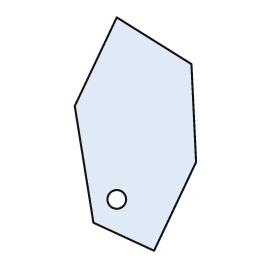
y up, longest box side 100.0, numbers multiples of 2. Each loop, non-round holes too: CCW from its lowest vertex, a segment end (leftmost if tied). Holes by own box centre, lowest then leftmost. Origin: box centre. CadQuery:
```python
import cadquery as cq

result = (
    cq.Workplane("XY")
    .moveTo(8.0, -50.0)
    .lineTo(26.0, -12.0)
    .lineTo(24.0, 30.0)
    .lineTo(-8.0, 50.0)
    .lineTo(-26.0, 12.0)
    .lineTo(-18.0, -38.0)
    .close()
    .moveTo(-8.0, -28.0)
    .circle(4.0)
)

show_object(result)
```